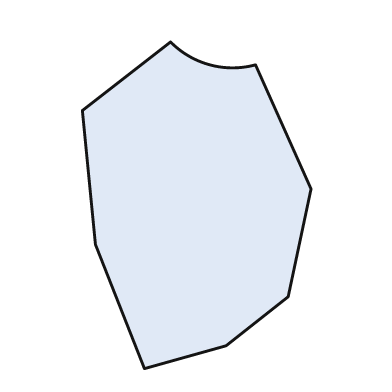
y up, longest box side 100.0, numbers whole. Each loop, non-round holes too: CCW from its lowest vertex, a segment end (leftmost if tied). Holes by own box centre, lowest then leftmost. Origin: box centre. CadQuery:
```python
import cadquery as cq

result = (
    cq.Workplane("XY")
    .moveTo(-16.0, -50.0)
    .lineTo(9.0, -43.0)
    .lineTo(28.0, -28.0)
    .lineTo(35.0, 5.0)
    .lineTo(18.0, 43.0)
    .threePointArc((4.0, 43.0), (-8.0, 50.0))
    .lineTo(-35.0, 29.0)
    .lineTo(-31.0, -12.0)
    .close()
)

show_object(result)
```